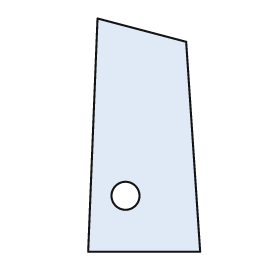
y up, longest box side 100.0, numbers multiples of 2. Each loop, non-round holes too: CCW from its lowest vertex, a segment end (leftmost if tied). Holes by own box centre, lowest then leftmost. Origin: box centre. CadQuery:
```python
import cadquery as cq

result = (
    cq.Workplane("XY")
    .moveTo(-24.0, -50.0)
    .lineTo(24.0, -50.0)
    .lineTo(18.0, 40.0)
    .lineTo(-20.0, 50.0)
    .close()
    .moveTo(-8.0, -26.0)
    .circle(6.0)
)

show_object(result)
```